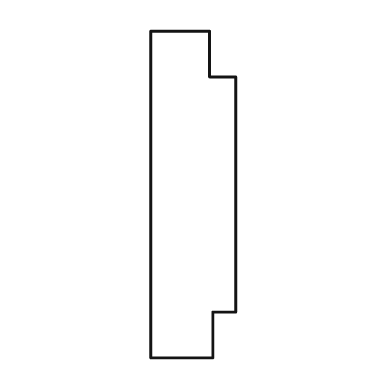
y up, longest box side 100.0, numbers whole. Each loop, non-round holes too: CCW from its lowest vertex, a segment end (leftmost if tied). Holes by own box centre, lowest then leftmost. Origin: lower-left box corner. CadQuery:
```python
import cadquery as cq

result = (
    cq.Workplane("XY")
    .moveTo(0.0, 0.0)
    .lineTo(19.0, 0.0)
    .lineTo(19.0, 14.0)
    .lineTo(26.0, 14.0)
    .lineTo(26.0, 86.0)
    .lineTo(18.0, 86.0)
    .lineTo(18.0, 100.0)
    .lineTo(0.0, 100.0)
    .close()
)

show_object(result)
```